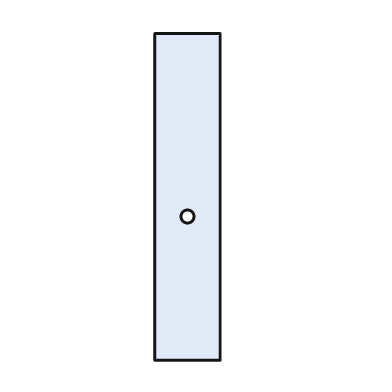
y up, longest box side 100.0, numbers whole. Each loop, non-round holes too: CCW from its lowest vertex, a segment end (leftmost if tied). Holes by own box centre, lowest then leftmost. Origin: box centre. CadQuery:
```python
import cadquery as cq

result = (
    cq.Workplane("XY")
    .moveTo(-10.0, -50.0)
    .lineTo(10.0, -50.0)
    .lineTo(10.0, 50.0)
    .lineTo(-10.0, 50.0)
    .close()
    .moveTo(0.0, -6.0)
    .circle(2.0)
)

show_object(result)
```